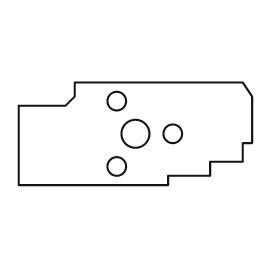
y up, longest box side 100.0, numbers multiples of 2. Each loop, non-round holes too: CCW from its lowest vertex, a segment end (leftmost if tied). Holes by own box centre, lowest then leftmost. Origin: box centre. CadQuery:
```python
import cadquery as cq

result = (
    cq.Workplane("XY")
    .moveTo(-50.0, -22.0)
    .lineTo(14.0, -22.0)
    .lineTo(14.0, -18.0)
    .lineTo(32.0, -18.0)
    .lineTo(32.0, -12.0)
    .lineTo(46.0, -12.0)
    .lineTo(46.0, -4.0)
    .lineTo(50.0, -4.0)
    .lineTo(50.0, 16.0)
    .lineTo(46.0, 22.0)
    .lineTo(-26.0, 22.0)
    .lineTo(-26.0, 16.0)
    .lineTo(-30.0, 12.0)
    .lineTo(-50.0, 12.0)
    .close()
    .moveTo(-8.0, -14.0)
    .circle(4.0)
    .moveTo(0.0, 0.0)
    .circle(6.0)
    .moveTo(16.0, 0.0)
    .circle(4.0)
    .moveTo(-8.0, 14.0)
    .circle(4.0)
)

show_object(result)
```